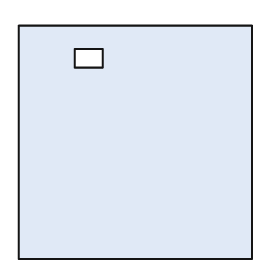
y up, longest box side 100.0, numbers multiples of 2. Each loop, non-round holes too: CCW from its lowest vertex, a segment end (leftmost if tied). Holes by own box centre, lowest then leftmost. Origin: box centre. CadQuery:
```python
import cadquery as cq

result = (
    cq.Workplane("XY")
    .moveTo(-50.0, -50.0)
    .lineTo(50.0, -50.0)
    .lineTo(50.0, 50.0)
    .lineTo(-50.0, 50.0)
    .close()
    .moveTo(-26.0, 32.0)
    .lineTo(-14.0, 32.0)
    .lineTo(-14.0, 40.0)
    .lineTo(-26.0, 40.0)
    .close()
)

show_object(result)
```